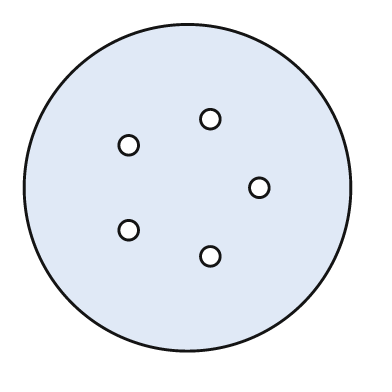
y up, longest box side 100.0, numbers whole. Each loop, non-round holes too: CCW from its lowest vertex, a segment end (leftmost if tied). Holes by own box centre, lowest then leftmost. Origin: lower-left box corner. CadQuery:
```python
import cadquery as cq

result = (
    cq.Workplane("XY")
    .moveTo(50.0, 50.0)
    .circle(50.0)
    .moveTo(57.0, 29.0)
    .circle(3.0)
    .moveTo(32.0, 37.0)
    .circle(3.0)
    .moveTo(72.0, 50.0)
    .circle(3.0)
    .moveTo(32.0, 63.0)
    .circle(3.0)
    .moveTo(57.0, 71.0)
    .circle(3.0)
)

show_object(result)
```